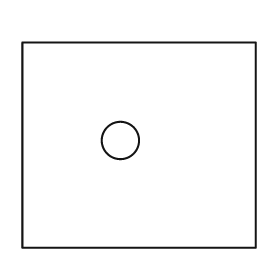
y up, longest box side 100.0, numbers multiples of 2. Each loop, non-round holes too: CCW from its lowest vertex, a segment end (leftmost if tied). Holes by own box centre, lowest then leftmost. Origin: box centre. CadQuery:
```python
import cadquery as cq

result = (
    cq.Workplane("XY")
    .moveTo(-50.0, -44.0)
    .lineTo(50.0, -44.0)
    .lineTo(50.0, 44.0)
    .lineTo(-50.0, 44.0)
    .close()
    .moveTo(-8.0, 2.0)
    .circle(8.0)
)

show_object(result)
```